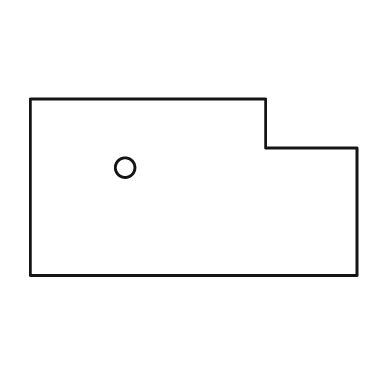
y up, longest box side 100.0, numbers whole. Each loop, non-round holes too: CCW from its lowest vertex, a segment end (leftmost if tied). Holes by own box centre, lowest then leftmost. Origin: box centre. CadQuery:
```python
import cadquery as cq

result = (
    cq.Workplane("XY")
    .moveTo(-50.0, -27.0)
    .lineTo(50.0, -27.0)
    .lineTo(50.0, 12.0)
    .lineTo(22.0, 12.0)
    .lineTo(22.0, 27.0)
    .lineTo(-50.0, 27.0)
    .close()
    .moveTo(-21.0, 6.0)
    .circle(3.0)
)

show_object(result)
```